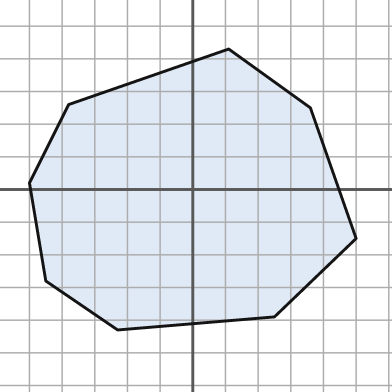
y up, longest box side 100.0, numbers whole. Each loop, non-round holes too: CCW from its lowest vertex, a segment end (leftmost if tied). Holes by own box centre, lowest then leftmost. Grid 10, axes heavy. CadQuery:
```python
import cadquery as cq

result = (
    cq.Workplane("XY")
    .moveTo(-23.0, -43.0)
    .lineTo(25.0, -39.0)
    .lineTo(50.0, -15.0)
    .lineTo(36.0, 25.0)
    .lineTo(11.0, 43.0)
    .lineTo(-38.0, 26.0)
    .lineTo(-50.0, 2.0)
    .lineTo(-45.0, -28.0)
    .close()
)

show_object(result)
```